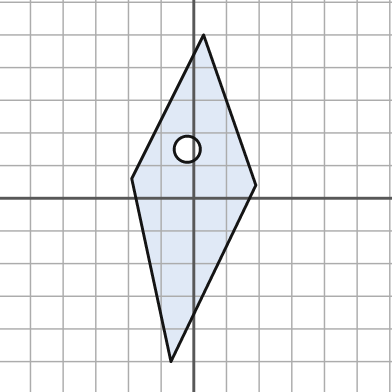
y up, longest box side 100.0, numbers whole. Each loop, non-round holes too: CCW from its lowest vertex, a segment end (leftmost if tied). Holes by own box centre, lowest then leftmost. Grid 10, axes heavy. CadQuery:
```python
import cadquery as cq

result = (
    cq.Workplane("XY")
    .moveTo(-7.0, -50.0)
    .lineTo(19.0, 4.0)
    .lineTo(3.0, 50.0)
    .lineTo(-19.0, 6.0)
    .close()
    .moveTo(-2.0, 15.0)
    .circle(4.0)
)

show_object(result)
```